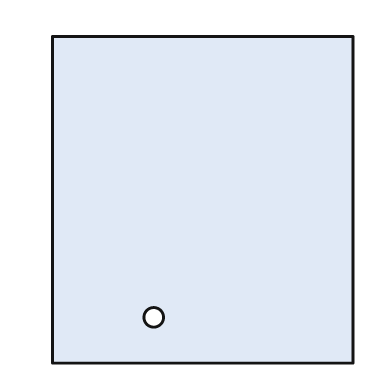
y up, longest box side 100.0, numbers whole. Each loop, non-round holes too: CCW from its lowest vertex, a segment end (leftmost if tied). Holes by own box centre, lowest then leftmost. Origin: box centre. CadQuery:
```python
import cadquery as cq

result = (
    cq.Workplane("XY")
    .moveTo(-46.0, -50.0)
    .lineTo(46.0, -50.0)
    .lineTo(46.0, 50.0)
    .lineTo(-46.0, 50.0)
    .close()
    .moveTo(-15.0, -36.0)
    .circle(3.0)
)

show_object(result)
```